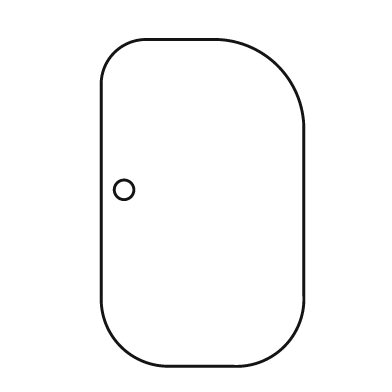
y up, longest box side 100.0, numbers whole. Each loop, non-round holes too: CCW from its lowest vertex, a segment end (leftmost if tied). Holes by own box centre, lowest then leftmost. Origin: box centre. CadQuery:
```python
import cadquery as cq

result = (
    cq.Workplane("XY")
    .moveTo(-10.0, -50.0)
    .lineTo(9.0, -50.0)
    .threePointArc((25.0, -44.0), (31.0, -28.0))
    .lineTo(31.0, 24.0)
    .threePointArc((23.0, 42.0), (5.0, 50.0))
    .lineTo(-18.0, 50.0)
    .threePointArc((-27.0, 46.0), (-31.0, 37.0))
    .lineTo(-31.0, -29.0)
    .threePointArc((-25.0, -44.0), (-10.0, -50.0))
    .close()
    .moveTo(-24.0, 4.0)
    .circle(3.0)
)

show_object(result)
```